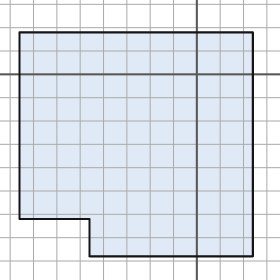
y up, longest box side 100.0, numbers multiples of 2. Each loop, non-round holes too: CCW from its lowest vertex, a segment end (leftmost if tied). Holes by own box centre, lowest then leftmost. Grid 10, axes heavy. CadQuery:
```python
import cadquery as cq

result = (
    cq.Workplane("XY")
    .moveTo(-46.0, -78.0)
    .lineTo(24.0, -78.0)
    .lineTo(24.0, 18.0)
    .lineTo(-76.0, 18.0)
    .lineTo(-76.0, -62.0)
    .lineTo(-46.0, -62.0)
    .close()
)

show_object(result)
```